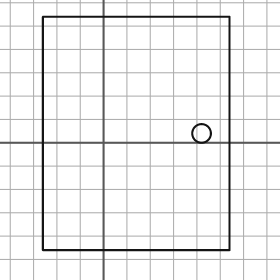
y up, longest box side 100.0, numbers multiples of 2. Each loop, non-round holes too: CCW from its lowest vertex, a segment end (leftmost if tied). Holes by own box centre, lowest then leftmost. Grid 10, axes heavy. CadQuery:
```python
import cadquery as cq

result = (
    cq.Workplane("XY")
    .moveTo(-26.0, -46.0)
    .lineTo(54.0, -46.0)
    .lineTo(54.0, 54.0)
    .lineTo(-26.0, 54.0)
    .close()
    .moveTo(42.0, 4.0)
    .circle(4.0)
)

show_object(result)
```